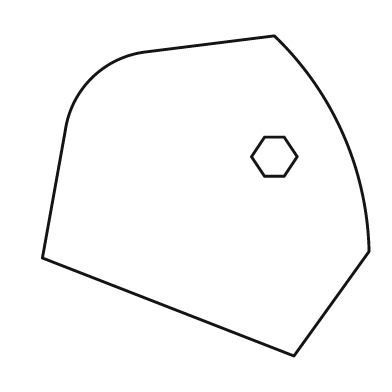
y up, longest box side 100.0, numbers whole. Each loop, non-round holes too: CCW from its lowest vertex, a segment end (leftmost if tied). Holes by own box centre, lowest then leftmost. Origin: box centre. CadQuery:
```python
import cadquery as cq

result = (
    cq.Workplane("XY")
    .moveTo(27.0, -49.0)
    .lineTo(50.0, -17.0)
    .threePointArc((42.0, 19.0), (21.0, 49.0))
    .lineTo(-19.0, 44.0)
    .threePointArc((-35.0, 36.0), (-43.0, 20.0))
    .lineTo(-50.0, -19.0)
    .close()
    .moveTo(18.0, 6.0)
    .lineTo(24.0, 6.0)
    .lineTo(28.0, 12.0)
    .lineTo(24.0, 18.0)
    .lineTo(18.0, 18.0)
    .lineTo(14.0, 12.0)
    .close()
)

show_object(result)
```